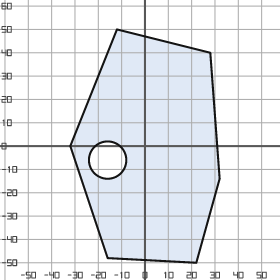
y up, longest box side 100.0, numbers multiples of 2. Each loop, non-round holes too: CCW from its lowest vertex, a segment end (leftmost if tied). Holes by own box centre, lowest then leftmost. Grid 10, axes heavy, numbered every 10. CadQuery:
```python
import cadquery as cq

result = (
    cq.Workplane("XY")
    .moveTo(22.0, -50.0)
    .lineTo(32.0, -14.0)
    .lineTo(28.0, 40.0)
    .lineTo(-12.0, 50.0)
    .lineTo(-32.0, 0.0)
    .lineTo(-16.0, -48.0)
    .close()
    .moveTo(-16.0, -6.0)
    .circle(8.0)
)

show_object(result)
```